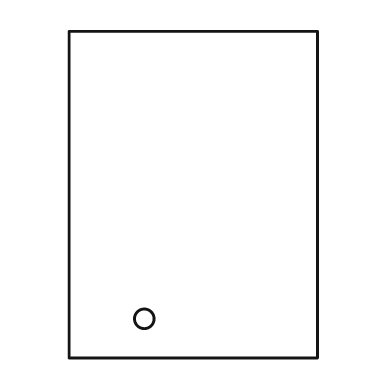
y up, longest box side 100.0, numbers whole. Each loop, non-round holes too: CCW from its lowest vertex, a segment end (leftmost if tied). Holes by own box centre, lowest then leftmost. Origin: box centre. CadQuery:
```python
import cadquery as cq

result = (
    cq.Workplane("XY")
    .moveTo(-38.0, -50.0)
    .lineTo(38.0, -50.0)
    .lineTo(38.0, 50.0)
    .lineTo(-38.0, 50.0)
    .close()
    .moveTo(-15.0, -38.0)
    .circle(3.0)
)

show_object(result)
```